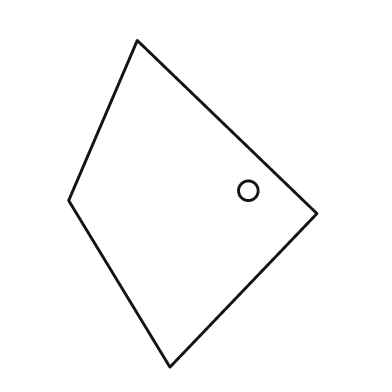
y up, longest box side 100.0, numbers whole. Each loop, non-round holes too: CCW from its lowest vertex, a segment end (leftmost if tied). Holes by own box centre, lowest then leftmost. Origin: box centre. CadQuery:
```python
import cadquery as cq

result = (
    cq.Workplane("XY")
    .moveTo(-7.0, -50.0)
    .lineTo(38.0, -3.0)
    .lineTo(-17.0, 50.0)
    .lineTo(-38.0, 1.0)
    .close()
    .moveTo(17.0, 4.0)
    .circle(3.0)
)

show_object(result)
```